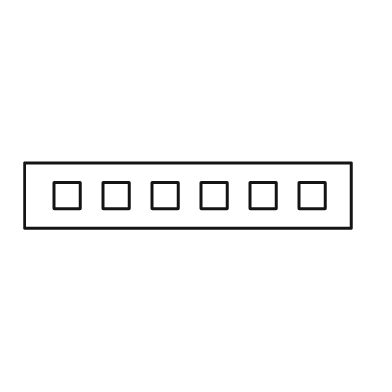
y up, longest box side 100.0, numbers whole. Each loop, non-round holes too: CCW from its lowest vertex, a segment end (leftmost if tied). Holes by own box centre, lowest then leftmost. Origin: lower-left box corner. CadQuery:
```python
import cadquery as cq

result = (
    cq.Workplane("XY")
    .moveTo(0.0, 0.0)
    .lineTo(100.0, 0.0)
    .lineTo(100.0, 20.0)
    .lineTo(0.0, 20.0)
    .close()
    .moveTo(9.0, 6.0)
    .lineTo(17.0, 6.0)
    .lineTo(17.0, 14.0)
    .lineTo(9.0, 14.0)
    .close()
    .moveTo(24.0, 6.0)
    .lineTo(32.0, 6.0)
    .lineTo(32.0, 14.0)
    .lineTo(24.0, 14.0)
    .close()
    .moveTo(39.0, 6.0)
    .lineTo(47.0, 6.0)
    .lineTo(47.0, 14.0)
    .lineTo(39.0, 14.0)
    .close()
    .moveTo(54.0, 6.0)
    .lineTo(62.0, 6.0)
    .lineTo(62.0, 14.0)
    .lineTo(54.0, 14.0)
    .close()
    .moveTo(69.0, 6.0)
    .lineTo(77.0, 6.0)
    .lineTo(77.0, 14.0)
    .lineTo(69.0, 14.0)
    .close()
    .moveTo(84.0, 6.0)
    .lineTo(92.0, 6.0)
    .lineTo(92.0, 14.0)
    .lineTo(84.0, 14.0)
    .close()
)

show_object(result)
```